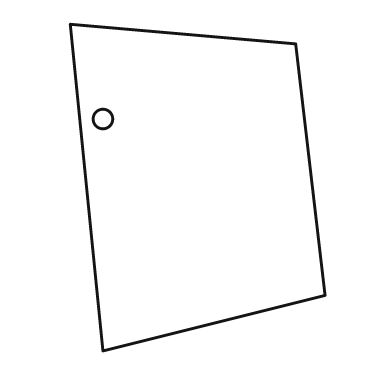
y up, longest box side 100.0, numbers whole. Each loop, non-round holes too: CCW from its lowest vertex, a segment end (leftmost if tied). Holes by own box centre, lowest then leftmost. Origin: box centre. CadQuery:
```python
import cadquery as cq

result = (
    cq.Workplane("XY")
    .moveTo(-29.0, -50.0)
    .lineTo(39.0, -33.0)
    .lineTo(30.0, 44.0)
    .lineTo(-39.0, 50.0)
    .close()
    .moveTo(-29.0, 21.0)
    .circle(3.0)
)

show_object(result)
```